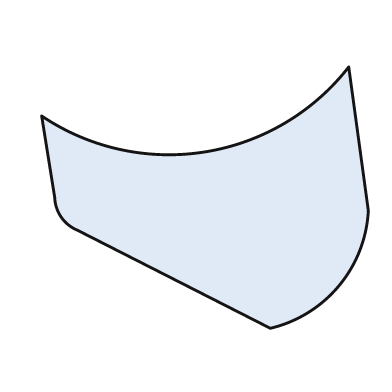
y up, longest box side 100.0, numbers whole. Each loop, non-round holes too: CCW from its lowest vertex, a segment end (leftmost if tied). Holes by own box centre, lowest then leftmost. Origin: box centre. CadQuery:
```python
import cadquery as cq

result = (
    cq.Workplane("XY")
    .moveTo(20.0, -40.0)
    .threePointArc((41.0, -27.0), (50.0, -4.0))
    .lineTo(44.0, 40.0)
    .threePointArc((0.0, 14.0), (-50.0, 25.0))
    .lineTo(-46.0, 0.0)
    .threePointArc((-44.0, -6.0), (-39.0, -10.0))
    .close()
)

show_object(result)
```